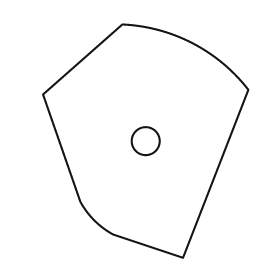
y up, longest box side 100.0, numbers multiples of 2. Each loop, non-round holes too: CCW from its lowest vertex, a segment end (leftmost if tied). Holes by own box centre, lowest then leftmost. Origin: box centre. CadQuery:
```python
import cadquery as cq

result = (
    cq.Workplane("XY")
    .moveTo(16.0, -50.0)
    .lineTo(44.0, 22.0)
    .threePointArc((20.0, 42.0), (-10.0, 50.0))
    .lineTo(-44.0, 20.0)
    .lineTo(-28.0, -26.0)
    .threePointArc((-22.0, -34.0), (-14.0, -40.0))
    .close()
    .moveTo(0.0, 0.0)
    .circle(6.0)
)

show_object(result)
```